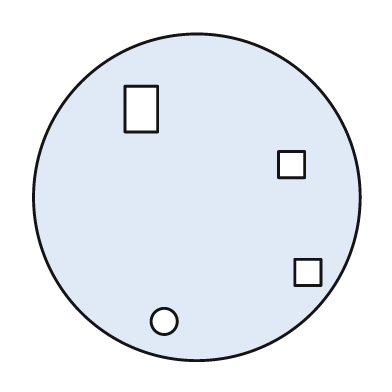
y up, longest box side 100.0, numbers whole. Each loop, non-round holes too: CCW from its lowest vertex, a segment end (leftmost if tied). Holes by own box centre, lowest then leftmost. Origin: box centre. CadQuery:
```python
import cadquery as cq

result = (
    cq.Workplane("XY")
    .moveTo(0.0, 0.0)
    .circle(50.0)
    .moveTo(-10.0, -38.0)
    .circle(4.0)
    .moveTo(30.0, -27.0)
    .lineTo(38.0, -27.0)
    .lineTo(38.0, -19.0)
    .lineTo(30.0, -19.0)
    .close()
    .moveTo(25.0, 6.0)
    .lineTo(33.0, 6.0)
    .lineTo(33.0, 14.0)
    .lineTo(25.0, 14.0)
    .close()
    .moveTo(-22.0, 20.0)
    .lineTo(-12.0, 20.0)
    .lineTo(-12.0, 34.0)
    .lineTo(-22.0, 34.0)
    .close()
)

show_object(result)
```